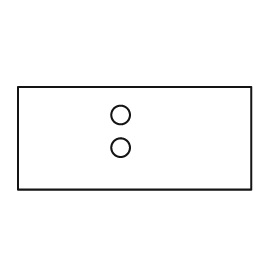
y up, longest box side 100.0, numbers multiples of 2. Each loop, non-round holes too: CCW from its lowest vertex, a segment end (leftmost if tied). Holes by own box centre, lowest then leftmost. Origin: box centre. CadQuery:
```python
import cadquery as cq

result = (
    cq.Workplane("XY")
    .moveTo(-50.0, -22.0)
    .lineTo(50.0, -22.0)
    .lineTo(50.0, 22.0)
    .lineTo(-50.0, 22.0)
    .close()
    .moveTo(-6.0, -4.0)
    .circle(4.0)
    .moveTo(-6.0, 10.0)
    .circle(4.0)
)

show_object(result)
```